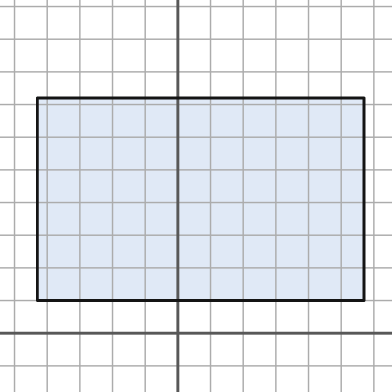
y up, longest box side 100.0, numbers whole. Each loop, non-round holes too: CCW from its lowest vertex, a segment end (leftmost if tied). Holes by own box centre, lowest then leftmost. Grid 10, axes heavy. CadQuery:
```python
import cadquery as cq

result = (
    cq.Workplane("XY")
    .moveTo(-43.0, 10.0)
    .lineTo(57.0, 10.0)
    .lineTo(57.0, 72.0)
    .lineTo(-43.0, 72.0)
    .close()
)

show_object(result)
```